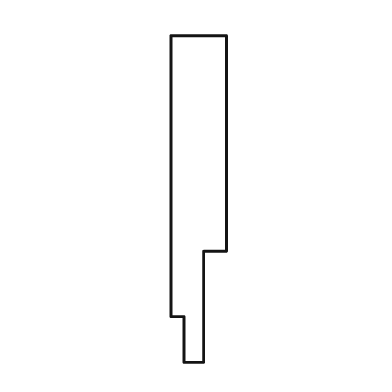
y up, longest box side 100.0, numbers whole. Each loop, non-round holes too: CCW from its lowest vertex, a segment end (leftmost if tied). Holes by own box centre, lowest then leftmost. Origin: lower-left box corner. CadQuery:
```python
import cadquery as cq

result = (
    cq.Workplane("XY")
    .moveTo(4.0, 0.0)
    .lineTo(10.0, 0.0)
    .lineTo(10.0, 34.0)
    .lineTo(17.0, 34.0)
    .lineTo(17.0, 100.0)
    .lineTo(0.0, 100.0)
    .lineTo(0.0, 14.0)
    .lineTo(4.0, 14.0)
    .close()
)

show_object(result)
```